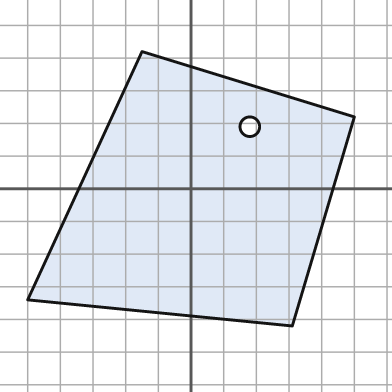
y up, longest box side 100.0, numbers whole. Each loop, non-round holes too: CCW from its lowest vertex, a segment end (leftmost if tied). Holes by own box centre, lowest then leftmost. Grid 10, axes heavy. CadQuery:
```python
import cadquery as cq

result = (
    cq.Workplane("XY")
    .moveTo(31.0, -42.0)
    .lineTo(50.0, 22.0)
    .lineTo(-15.0, 42.0)
    .lineTo(-50.0, -34.0)
    .close()
    .moveTo(18.0, 19.0)
    .circle(3.0)
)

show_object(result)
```